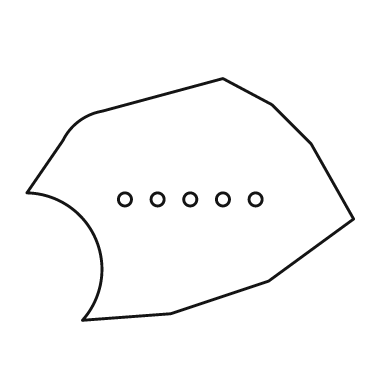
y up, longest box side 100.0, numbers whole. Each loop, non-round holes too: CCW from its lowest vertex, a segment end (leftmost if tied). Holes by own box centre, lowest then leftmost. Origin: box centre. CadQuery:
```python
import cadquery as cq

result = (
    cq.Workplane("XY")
    .moveTo(-33.0, -37.0)
    .lineTo(-6.0, -35.0)
    .lineTo(24.0, -25.0)
    .lineTo(50.0, -6.0)
    .lineTo(37.0, 17.0)
    .lineTo(25.0, 29.0)
    .lineTo(10.0, 37.0)
    .lineTo(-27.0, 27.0)
    .threePointArc((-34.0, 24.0), (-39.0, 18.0))
    .lineTo(-50.0, 2.0)
    .threePointArc((-29.0, -12.0), (-33.0, -37.0))
    .close()
    .moveTo(-20.0, 0.0)
    .circle(2.0)
    .moveTo(-10.0, 0.0)
    .circle(2.0)
    .moveTo(0.0, 0.0)
    .circle(2.0)
    .moveTo(10.0, 0.0)
    .circle(2.0)
    .moveTo(20.0, 0.0)
    .circle(2.0)
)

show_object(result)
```